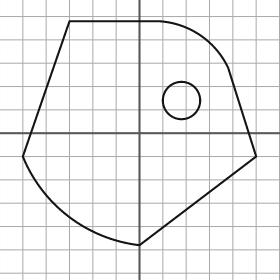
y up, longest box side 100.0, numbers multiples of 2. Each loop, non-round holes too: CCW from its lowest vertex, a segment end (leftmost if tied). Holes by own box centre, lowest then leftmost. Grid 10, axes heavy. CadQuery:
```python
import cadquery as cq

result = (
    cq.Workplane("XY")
    .moveTo(0.0, -48.0)
    .lineTo(50.0, -10.0)
    .lineTo(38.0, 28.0)
    .threePointArc((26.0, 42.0), (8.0, 48.0))
    .lineTo(-30.0, 48.0)
    .lineTo(-50.0, -10.0)
    .threePointArc((-30.0, -36.0), (0.0, -48.0))
    .close()
    .moveTo(18.0, 14.0)
    .circle(8.0)
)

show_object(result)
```